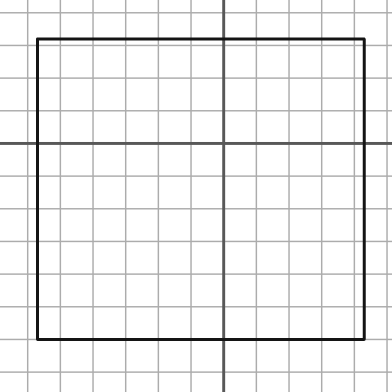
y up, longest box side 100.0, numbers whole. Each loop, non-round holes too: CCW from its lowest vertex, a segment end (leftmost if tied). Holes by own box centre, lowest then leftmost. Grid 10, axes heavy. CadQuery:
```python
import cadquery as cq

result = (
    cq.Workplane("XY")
    .moveTo(-57.0, -60.0)
    .lineTo(43.0, -60.0)
    .lineTo(43.0, 32.0)
    .lineTo(-57.0, 32.0)
    .close()
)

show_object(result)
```